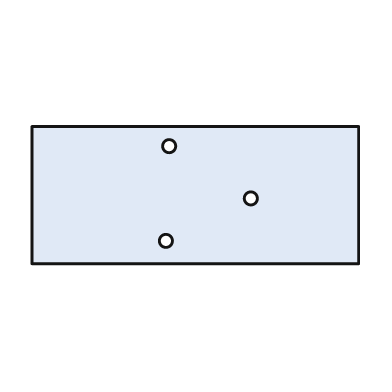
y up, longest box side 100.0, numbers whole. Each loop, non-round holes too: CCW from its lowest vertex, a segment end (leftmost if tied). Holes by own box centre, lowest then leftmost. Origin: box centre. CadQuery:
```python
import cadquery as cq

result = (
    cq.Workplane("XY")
    .moveTo(-50.0, -21.0)
    .lineTo(50.0, -21.0)
    .lineTo(50.0, 21.0)
    .lineTo(-50.0, 21.0)
    .close()
    .moveTo(-9.0, -14.0)
    .circle(2.0)
    .moveTo(17.0, -1.0)
    .circle(2.0)
    .moveTo(-8.0, 15.0)
    .circle(2.0)
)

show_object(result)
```